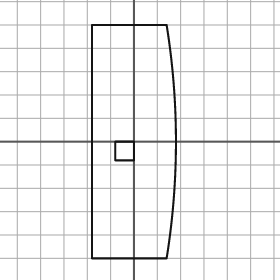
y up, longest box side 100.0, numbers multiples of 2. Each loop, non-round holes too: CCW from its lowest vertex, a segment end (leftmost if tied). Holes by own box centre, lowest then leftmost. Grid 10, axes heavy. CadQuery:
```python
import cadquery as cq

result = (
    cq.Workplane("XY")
    .moveTo(-18.0, -50.0)
    .lineTo(14.0, -50.0)
    .threePointArc((18.0, 0.0), (14.0, 50.0))
    .lineTo(-18.0, 50.0)
    .close()
    .moveTo(-8.0, -8.0)
    .lineTo(0.0, -8.0)
    .lineTo(0.0, 0.0)
    .lineTo(-8.0, 0.0)
    .close()
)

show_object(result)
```